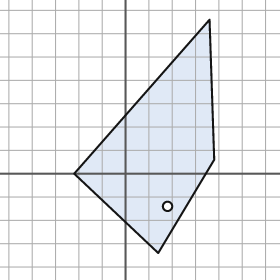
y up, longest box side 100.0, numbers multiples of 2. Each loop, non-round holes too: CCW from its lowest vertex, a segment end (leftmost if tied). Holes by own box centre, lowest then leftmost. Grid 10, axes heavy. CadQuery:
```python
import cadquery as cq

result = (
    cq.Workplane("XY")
    .moveTo(14.0, -34.0)
    .lineTo(38.0, 6.0)
    .lineTo(36.0, 66.0)
    .lineTo(-22.0, 0.0)
    .close()
    .moveTo(18.0, -14.0)
    .circle(2.0)
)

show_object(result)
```